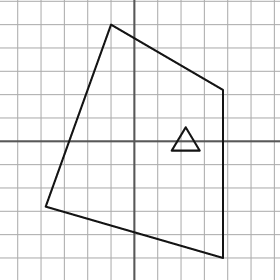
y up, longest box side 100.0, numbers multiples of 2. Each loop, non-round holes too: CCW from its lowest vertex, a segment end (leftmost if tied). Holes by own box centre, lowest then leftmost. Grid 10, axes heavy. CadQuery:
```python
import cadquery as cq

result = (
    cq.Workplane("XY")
    .moveTo(38.0, -50.0)
    .lineTo(38.0, 22.0)
    .lineTo(-10.0, 50.0)
    .lineTo(-38.0, -28.0)
    .close()
    .moveTo(16.0, -4.0)
    .lineTo(28.0, -4.0)
    .lineTo(22.0, 6.0)
    .close()
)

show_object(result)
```